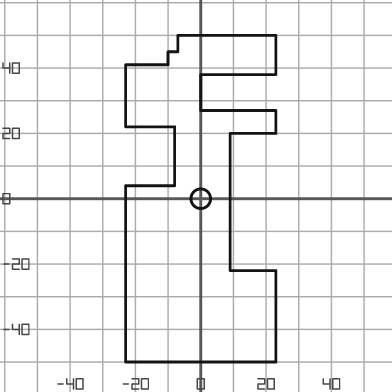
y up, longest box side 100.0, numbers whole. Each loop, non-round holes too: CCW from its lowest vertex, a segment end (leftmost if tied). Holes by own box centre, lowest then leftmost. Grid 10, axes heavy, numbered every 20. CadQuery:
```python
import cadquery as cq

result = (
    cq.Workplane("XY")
    .moveTo(-23.0, -50.0)
    .lineTo(23.0, -50.0)
    .lineTo(23.0, -22.0)
    .lineTo(9.0, -22.0)
    .lineTo(9.0, 20.0)
    .lineTo(23.0, 20.0)
    .lineTo(23.0, 27.0)
    .lineTo(0.0, 27.0)
    .lineTo(0.0, 38.0)
    .lineTo(23.0, 38.0)
    .lineTo(23.0, 50.0)
    .lineTo(-7.0, 50.0)
    .lineTo(-7.0, 45.0)
    .lineTo(-10.0, 45.0)
    .lineTo(-10.0, 41.0)
    .lineTo(-23.0, 41.0)
    .lineTo(-23.0, 22.0)
    .lineTo(-8.0, 22.0)
    .lineTo(-8.0, 4.0)
    .lineTo(-23.0, 4.0)
    .close()
    .moveTo(0.0, 0.0)
    .circle(3.0)
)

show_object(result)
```